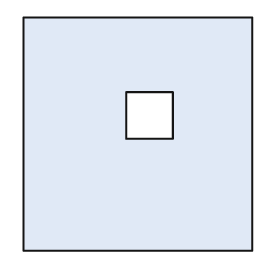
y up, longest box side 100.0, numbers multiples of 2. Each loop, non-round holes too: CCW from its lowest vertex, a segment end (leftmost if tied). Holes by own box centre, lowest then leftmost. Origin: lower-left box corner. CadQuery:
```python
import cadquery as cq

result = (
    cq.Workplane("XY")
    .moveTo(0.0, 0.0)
    .lineTo(98.0, 0.0)
    .lineTo(98.0, 100.0)
    .lineTo(0.0, 100.0)
    .close()
    .moveTo(44.0, 48.0)
    .lineTo(64.0, 48.0)
    .lineTo(64.0, 68.0)
    .lineTo(44.0, 68.0)
    .close()
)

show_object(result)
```